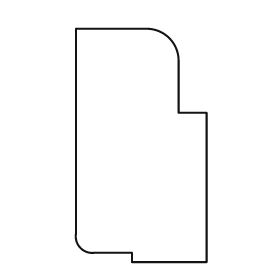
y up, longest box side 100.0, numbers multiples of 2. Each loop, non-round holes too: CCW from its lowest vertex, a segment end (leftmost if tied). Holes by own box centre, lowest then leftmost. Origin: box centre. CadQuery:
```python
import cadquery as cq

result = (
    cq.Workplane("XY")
    .moveTo(-4.0, -50.0)
    .lineTo(28.0, -50.0)
    .lineTo(28.0, 14.0)
    .lineTo(16.0, 14.0)
    .lineTo(16.0, 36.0)
    .threePointArc((12.0, 46.0), (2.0, 50.0))
    .lineTo(-28.0, 50.0)
    .lineTo(-28.0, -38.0)
    .threePointArc((-26.0, -44.0), (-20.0, -46.0))
    .lineTo(-4.0, -46.0)
    .close()
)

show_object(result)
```